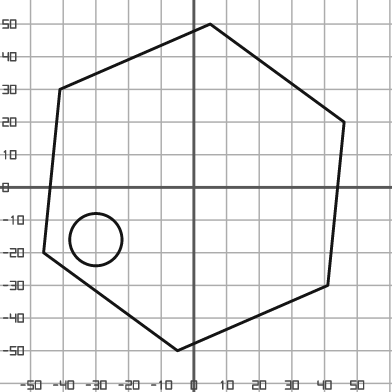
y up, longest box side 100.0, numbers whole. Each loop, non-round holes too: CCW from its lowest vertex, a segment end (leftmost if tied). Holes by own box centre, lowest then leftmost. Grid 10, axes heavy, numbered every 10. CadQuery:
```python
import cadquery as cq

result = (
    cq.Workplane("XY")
    .moveTo(-5.0, -50.0)
    .lineTo(41.0, -30.0)
    .lineTo(46.0, 20.0)
    .lineTo(5.0, 50.0)
    .lineTo(-41.0, 30.0)
    .lineTo(-46.0, -20.0)
    .close()
    .moveTo(-30.0, -16.0)
    .circle(8.0)
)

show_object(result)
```